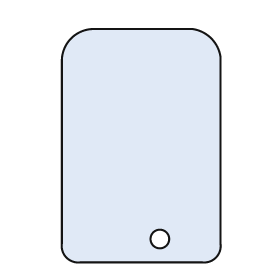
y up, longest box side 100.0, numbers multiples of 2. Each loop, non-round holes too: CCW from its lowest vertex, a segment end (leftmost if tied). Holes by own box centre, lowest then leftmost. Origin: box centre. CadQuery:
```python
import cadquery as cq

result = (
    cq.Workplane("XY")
    .moveTo(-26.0, -50.0)
    .lineTo(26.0, -50.0)
    .threePointArc((32.0, -48.0), (34.0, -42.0))
    .lineTo(34.0, 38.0)
    .threePointArc((30.0, 46.0), (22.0, 50.0))
    .lineTo(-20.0, 50.0)
    .threePointArc((-30.0, 46.0), (-34.0, 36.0))
    .lineTo(-34.0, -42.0)
    .threePointArc((-32.0, -48.0), (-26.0, -50.0))
    .close()
    .moveTo(8.0, -40.0)
    .circle(4.0)
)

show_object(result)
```